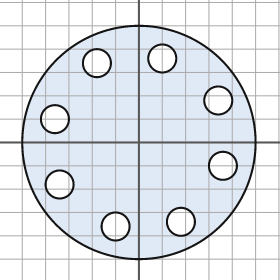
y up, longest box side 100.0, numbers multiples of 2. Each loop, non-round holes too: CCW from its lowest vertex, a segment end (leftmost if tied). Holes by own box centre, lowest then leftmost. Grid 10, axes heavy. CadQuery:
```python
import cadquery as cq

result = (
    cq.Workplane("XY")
    .moveTo(0.0, 0.0)
    .circle(50.0)
    .moveTo(-10.0, -36.0)
    .circle(6.0)
    .moveTo(18.0, -34.0)
    .circle(6.0)
    .moveTo(-34.0, -18.0)
    .circle(6.0)
    .moveTo(36.0, -10.0)
    .circle(6.0)
    .moveTo(-36.0, 10.0)
    .circle(6.0)
    .moveTo(34.0, 18.0)
    .circle(6.0)
    .moveTo(-18.0, 34.0)
    .circle(6.0)
    .moveTo(10.0, 36.0)
    .circle(6.0)
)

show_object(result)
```